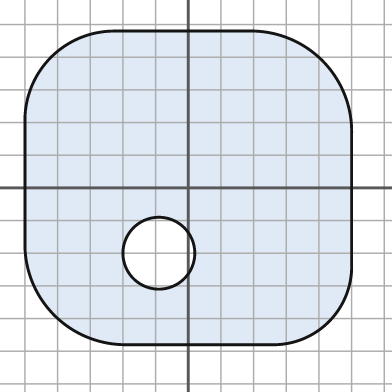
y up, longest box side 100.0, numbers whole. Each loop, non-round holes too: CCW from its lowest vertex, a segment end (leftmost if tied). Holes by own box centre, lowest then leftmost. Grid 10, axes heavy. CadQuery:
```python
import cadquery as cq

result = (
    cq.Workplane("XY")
    .moveTo(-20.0, -48.0)
    .lineTo(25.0, -48.0)
    .threePointArc((43.0, -41.0), (50.0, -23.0))
    .lineTo(50.0, 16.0)
    .threePointArc((41.0, 39.0), (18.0, 48.0))
    .lineTo(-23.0, 48.0)
    .threePointArc((-42.0, 40.0), (-50.0, 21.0))
    .lineTo(-50.0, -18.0)
    .threePointArc((-41.0, -39.0), (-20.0, -48.0))
    .close()
    .moveTo(-9.0, -20.0)
    .circle(11.0)
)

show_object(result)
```